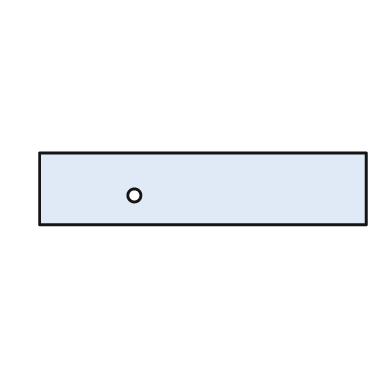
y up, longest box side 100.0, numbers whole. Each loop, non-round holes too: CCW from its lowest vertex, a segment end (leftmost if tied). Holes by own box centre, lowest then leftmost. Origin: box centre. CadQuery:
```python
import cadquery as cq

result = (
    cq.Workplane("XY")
    .moveTo(-50.0, -11.0)
    .lineTo(50.0, -11.0)
    .lineTo(50.0, 11.0)
    .lineTo(-50.0, 11.0)
    .close()
    .moveTo(-21.0, -2.0)
    .circle(2.0)
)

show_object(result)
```